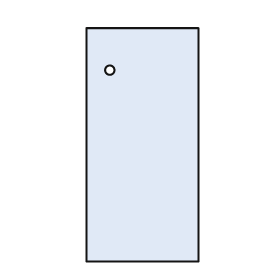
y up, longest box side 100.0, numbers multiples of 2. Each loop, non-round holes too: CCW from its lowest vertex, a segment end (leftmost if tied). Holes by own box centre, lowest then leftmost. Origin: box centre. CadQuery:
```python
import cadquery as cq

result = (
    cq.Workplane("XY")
    .moveTo(-24.0, -50.0)
    .lineTo(24.0, -50.0)
    .lineTo(24.0, 50.0)
    .lineTo(-24.0, 50.0)
    .close()
    .moveTo(-14.0, 32.0)
    .circle(2.0)
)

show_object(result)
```